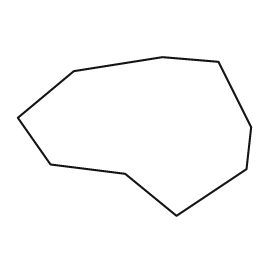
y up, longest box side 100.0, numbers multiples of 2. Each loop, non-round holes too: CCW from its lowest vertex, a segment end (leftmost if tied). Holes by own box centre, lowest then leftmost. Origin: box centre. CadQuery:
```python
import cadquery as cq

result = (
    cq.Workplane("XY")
    .moveTo(18.0, -34.0)
    .lineTo(48.0, -14.0)
    .lineTo(50.0, 4.0)
    .lineTo(36.0, 32.0)
    .lineTo(12.0, 34.0)
    .lineTo(-26.0, 28.0)
    .lineTo(-50.0, 8.0)
    .lineTo(-36.0, -12.0)
    .lineTo(-4.0, -16.0)
    .close()
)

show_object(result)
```